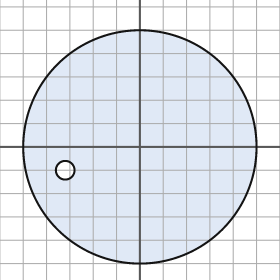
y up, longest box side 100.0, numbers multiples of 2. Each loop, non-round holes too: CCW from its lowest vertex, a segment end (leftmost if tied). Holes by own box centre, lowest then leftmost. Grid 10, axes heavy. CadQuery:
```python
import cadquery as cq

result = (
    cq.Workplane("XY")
    .moveTo(0.0, 0.0)
    .circle(50.0)
    .moveTo(-32.0, -10.0)
    .circle(4.0)
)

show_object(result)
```